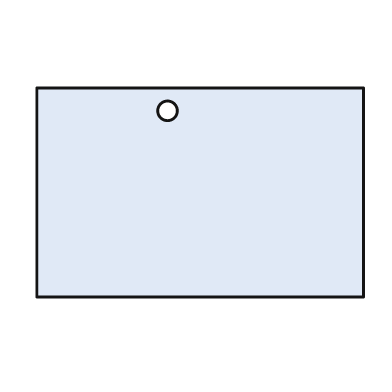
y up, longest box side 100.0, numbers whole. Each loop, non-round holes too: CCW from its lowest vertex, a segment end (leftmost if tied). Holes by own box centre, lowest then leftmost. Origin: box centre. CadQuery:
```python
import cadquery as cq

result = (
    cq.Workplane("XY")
    .moveTo(-50.0, -32.0)
    .lineTo(50.0, -32.0)
    .lineTo(50.0, 32.0)
    .lineTo(-50.0, 32.0)
    .close()
    .moveTo(-10.0, 25.0)
    .circle(3.0)
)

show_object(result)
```